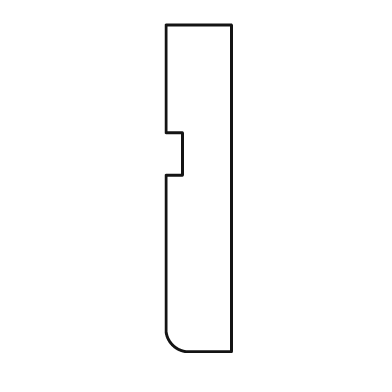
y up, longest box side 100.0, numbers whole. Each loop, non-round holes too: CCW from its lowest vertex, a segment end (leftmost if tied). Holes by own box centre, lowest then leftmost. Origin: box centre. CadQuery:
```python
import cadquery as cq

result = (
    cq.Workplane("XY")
    .moveTo(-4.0, -50.0)
    .lineTo(10.0, -50.0)
    .lineTo(10.0, 50.0)
    .lineTo(-10.0, 50.0)
    .lineTo(-10.0, 17.0)
    .lineTo(-5.0, 17.0)
    .lineTo(-5.0, 4.0)
    .lineTo(-10.0, 4.0)
    .lineTo(-10.0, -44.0)
    .threePointArc((-8.0, -48.0), (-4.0, -50.0))
    .close()
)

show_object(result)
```